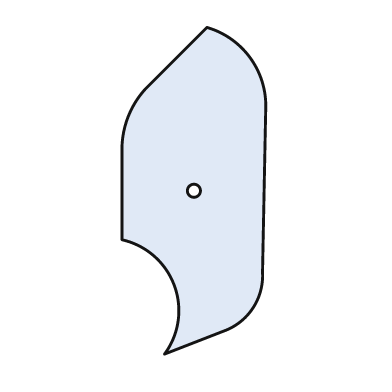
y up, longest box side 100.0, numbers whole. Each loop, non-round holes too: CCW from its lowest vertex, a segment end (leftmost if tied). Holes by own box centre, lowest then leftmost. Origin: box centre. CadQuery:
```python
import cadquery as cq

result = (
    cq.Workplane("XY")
    .moveTo(-9.0, -50.0)
    .lineTo(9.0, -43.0)
    .threePointArc((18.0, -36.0), (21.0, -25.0))
    .lineTo(22.0, 26.0)
    .threePointArc((17.0, 41.0), (4.0, 50.0))
    .lineTo(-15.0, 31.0)
    .threePointArc((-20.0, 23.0), (-22.0, 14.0))
    .lineTo(-22.0, -15.0)
    .threePointArc((-6.0, -29.0), (-9.0, -50.0))
    .close()
    .moveTo(0.0, 0.0)
    .circle(2.0)
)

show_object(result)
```